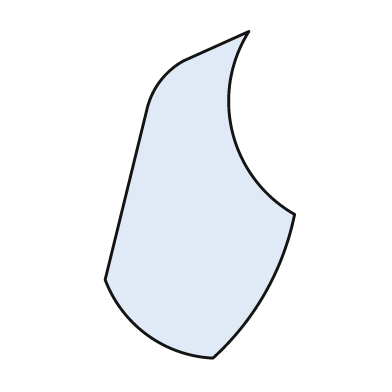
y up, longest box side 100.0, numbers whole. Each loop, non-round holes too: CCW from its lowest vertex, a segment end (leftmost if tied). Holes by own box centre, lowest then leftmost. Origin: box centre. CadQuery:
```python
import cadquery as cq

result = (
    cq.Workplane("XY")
    .moveTo(4.0, -50.0)
    .threePointArc((20.0, -30.0), (29.0, -6.0))
    .threePointArc((10.0, 19.0), (15.0, 50.0))
    .lineTo(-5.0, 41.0)
    .threePointArc((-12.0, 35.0), (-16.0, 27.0))
    .lineTo(-29.0, -26.0)
    .threePointArc((-16.0, -43.0), (4.0, -50.0))
    .close()
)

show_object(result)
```